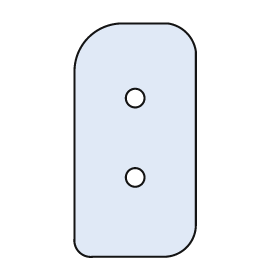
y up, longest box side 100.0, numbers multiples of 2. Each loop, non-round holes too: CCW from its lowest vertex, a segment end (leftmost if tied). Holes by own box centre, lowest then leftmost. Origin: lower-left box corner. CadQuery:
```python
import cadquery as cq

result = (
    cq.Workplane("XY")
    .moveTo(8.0, 0.0)
    .lineTo(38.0, 0.0)
    .threePointArc((48.0, 4.0), (52.0, 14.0))
    .lineTo(52.0, 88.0)
    .threePointArc((48.0, 96.0), (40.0, 100.0))
    .lineTo(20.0, 100.0)
    .threePointArc((6.0, 94.0), (0.0, 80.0))
    .lineTo(0.0, 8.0)
    .threePointArc((2.0, 2.0), (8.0, 0.0))
    .close()
    .moveTo(26.0, 34.0)
    .circle(4.0)
    .moveTo(26.0, 68.0)
    .circle(4.0)
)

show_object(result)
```